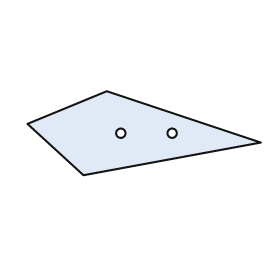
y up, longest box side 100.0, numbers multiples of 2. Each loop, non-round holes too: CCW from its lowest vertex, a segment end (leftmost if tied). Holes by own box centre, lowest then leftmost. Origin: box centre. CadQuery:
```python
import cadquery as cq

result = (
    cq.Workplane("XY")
    .moveTo(-26.0, -18.0)
    .lineTo(50.0, -4.0)
    .lineTo(-16.0, 18.0)
    .lineTo(-50.0, 4.0)
    .close()
    .moveTo(-10.0, 0.0)
    .circle(2.0)
    .moveTo(12.0, 0.0)
    .circle(2.0)
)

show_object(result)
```